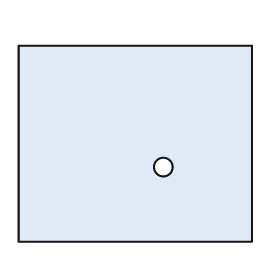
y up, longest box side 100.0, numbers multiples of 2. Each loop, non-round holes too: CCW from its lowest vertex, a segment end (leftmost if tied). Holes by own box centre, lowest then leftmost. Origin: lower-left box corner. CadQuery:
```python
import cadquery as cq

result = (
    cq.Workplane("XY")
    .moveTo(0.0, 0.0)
    .lineTo(100.0, 0.0)
    .lineTo(100.0, 84.0)
    .lineTo(0.0, 84.0)
    .close()
    .moveTo(62.0, 32.0)
    .circle(4.0)
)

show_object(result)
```